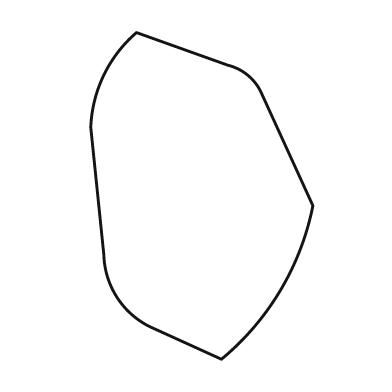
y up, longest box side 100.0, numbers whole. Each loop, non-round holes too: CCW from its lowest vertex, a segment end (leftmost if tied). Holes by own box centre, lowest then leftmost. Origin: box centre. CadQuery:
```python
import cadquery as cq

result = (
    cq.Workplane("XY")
    .moveTo(6.0, -50.0)
    .threePointArc((24.0, -29.0), (34.0, -3.0))
    .lineTo(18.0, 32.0)
    .threePointArc((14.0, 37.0), (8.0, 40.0))
    .lineTo(-20.0, 50.0)
    .threePointArc((-30.0, 37.0), (-34.0, 21.0))
    .lineTo(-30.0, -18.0)
    .threePointArc((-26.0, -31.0), (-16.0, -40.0))
    .close()
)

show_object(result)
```